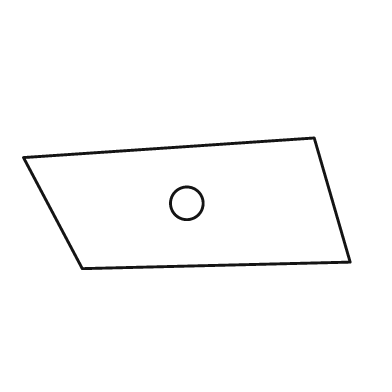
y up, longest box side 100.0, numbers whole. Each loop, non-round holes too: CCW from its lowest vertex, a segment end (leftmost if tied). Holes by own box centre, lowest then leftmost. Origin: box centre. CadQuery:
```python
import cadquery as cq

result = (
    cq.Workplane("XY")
    .moveTo(-32.0, -20.0)
    .lineTo(50.0, -18.0)
    .lineTo(39.0, 20.0)
    .lineTo(-50.0, 14.0)
    .close()
    .moveTo(0.0, 0.0)
    .circle(5.0)
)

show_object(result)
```